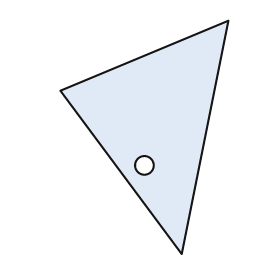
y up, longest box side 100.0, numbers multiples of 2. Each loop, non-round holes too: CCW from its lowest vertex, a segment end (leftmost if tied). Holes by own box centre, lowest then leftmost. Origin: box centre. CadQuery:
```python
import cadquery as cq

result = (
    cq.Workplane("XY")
    .moveTo(16.0, -50.0)
    .lineTo(36.0, 50.0)
    .lineTo(-36.0, 20.0)
    .close()
    .moveTo(0.0, -12.0)
    .circle(4.0)
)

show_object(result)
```